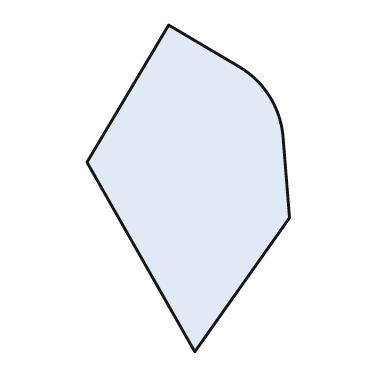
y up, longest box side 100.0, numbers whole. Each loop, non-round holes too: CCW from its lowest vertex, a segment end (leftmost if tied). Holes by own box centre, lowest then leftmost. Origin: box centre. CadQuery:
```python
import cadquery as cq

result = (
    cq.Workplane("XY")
    .moveTo(2.0, -50.0)
    .lineTo(31.0, -9.0)
    .lineTo(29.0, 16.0)
    .threePointArc((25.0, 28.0), (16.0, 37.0))
    .lineTo(-6.0, 50.0)
    .lineTo(-31.0, 8.0)
    .close()
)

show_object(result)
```